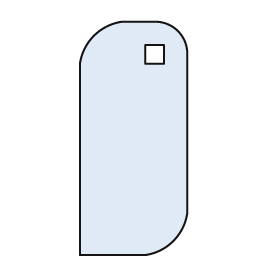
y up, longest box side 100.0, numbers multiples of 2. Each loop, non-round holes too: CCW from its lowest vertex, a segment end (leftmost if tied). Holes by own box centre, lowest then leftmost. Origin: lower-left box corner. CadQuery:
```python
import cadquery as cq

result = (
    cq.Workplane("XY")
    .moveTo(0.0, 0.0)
    .lineTo(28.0, 0.0)
    .threePointArc((40.0, 6.0), (46.0, 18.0))
    .lineTo(46.0, 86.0)
    .threePointArc((42.0, 96.0), (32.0, 100.0))
    .lineTo(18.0, 100.0)
    .threePointArc((6.0, 94.0), (0.0, 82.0))
    .close()
    .moveTo(28.0, 82.0)
    .lineTo(36.0, 82.0)
    .lineTo(36.0, 90.0)
    .lineTo(28.0, 90.0)
    .close()
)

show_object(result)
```